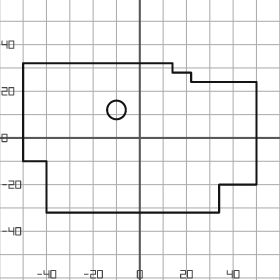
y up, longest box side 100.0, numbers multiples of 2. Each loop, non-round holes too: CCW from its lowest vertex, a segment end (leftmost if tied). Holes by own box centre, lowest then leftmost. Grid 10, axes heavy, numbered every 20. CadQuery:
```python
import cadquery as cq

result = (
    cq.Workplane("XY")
    .moveTo(-40.0, -32.0)
    .lineTo(34.0, -32.0)
    .lineTo(34.0, -20.0)
    .lineTo(50.0, -20.0)
    .lineTo(50.0, 24.0)
    .lineTo(22.0, 24.0)
    .lineTo(22.0, 28.0)
    .lineTo(14.0, 28.0)
    .lineTo(14.0, 32.0)
    .lineTo(-50.0, 32.0)
    .lineTo(-50.0, -10.0)
    .lineTo(-40.0, -10.0)
    .close()
    .moveTo(-10.0, 12.0)
    .circle(4.0)
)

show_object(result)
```